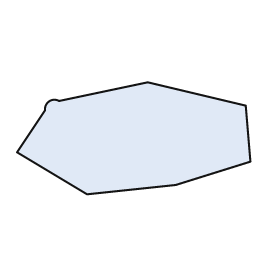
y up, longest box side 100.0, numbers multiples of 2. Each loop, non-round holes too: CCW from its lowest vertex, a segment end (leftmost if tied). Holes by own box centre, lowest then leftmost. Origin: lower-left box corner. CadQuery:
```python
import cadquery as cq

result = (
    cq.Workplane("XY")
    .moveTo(30.0, 0.0)
    .lineTo(68.0, 4.0)
    .lineTo(100.0, 14.0)
    .lineTo(98.0, 38.0)
    .lineTo(56.0, 48.0)
    .lineTo(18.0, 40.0)
    .threePointArc((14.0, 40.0), (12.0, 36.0))
    .lineTo(0.0, 18.0)
    .close()
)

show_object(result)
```